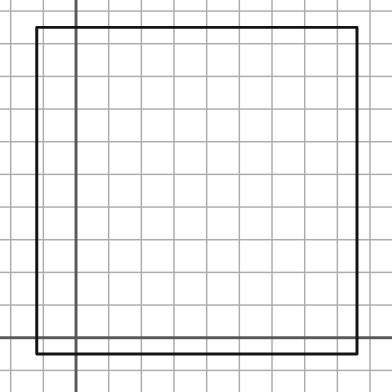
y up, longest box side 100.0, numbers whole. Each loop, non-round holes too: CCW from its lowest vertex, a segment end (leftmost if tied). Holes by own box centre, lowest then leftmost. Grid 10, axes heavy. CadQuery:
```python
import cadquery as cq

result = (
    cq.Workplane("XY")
    .moveTo(-12.0, -5.0)
    .lineTo(86.0, -5.0)
    .lineTo(86.0, 95.0)
    .lineTo(-12.0, 95.0)
    .close()
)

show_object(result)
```